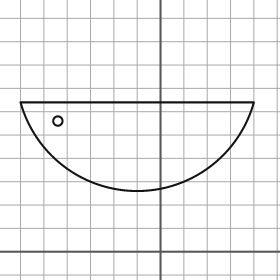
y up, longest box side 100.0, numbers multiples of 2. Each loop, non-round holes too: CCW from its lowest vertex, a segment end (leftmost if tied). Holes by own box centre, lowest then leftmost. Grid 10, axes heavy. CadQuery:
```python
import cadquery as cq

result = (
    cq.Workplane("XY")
    .moveTo(-60.0, 64.0)
    .threePointArc((-10.0, 26.0), (40.0, 64.0))
    .close()
    .moveTo(-44.0, 56.0)
    .circle(2.0)
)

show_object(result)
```